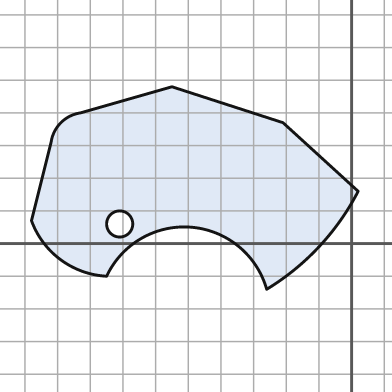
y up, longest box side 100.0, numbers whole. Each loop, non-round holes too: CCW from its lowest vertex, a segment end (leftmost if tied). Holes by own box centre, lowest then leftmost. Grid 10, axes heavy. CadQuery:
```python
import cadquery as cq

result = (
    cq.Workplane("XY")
    .moveTo(-26.0, -14.0)
    .threePointArc((-10.0, -1.0), (2.0, 16.0))
    .lineTo(-21.0, 37.0)
    .lineTo(-55.0, 48.0)
    .lineTo(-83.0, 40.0)
    .threePointArc((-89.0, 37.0), (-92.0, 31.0))
    .lineTo(-98.0, 7.0)
    .threePointArc((-89.0, -5.0), (-75.0, -10.0))
    .threePointArc((-49.0, 5.0), (-26.0, -14.0))
    .close()
    .moveTo(-71.0, 6.0)
    .circle(4.0)
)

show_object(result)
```